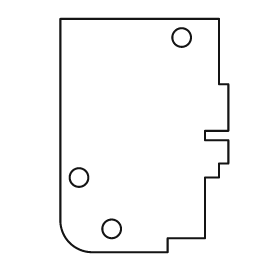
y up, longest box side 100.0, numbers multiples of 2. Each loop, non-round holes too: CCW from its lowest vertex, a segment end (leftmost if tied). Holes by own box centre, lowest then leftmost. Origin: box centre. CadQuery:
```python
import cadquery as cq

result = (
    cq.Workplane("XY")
    .moveTo(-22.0, -50.0)
    .lineTo(10.0, -50.0)
    .lineTo(10.0, -44.0)
    .lineTo(26.0, -44.0)
    .lineTo(26.0, -18.0)
    .lineTo(32.0, -18.0)
    .lineTo(32.0, -12.0)
    .lineTo(36.0, -12.0)
    .lineTo(36.0, -2.0)
    .lineTo(26.0, -2.0)
    .lineTo(26.0, 2.0)
    .lineTo(36.0, 2.0)
    .lineTo(36.0, 22.0)
    .lineTo(32.0, 22.0)
    .lineTo(32.0, 50.0)
    .lineTo(-36.0, 50.0)
    .lineTo(-36.0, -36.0)
    .threePointArc((-32.0, -46.0), (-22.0, -50.0))
    .close()
    .moveTo(-14.0, -40.0)
    .circle(4.0)
    .moveTo(-28.0, -18.0)
    .circle(4.0)
    .moveTo(16.0, 42.0)
    .circle(4.0)
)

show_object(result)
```